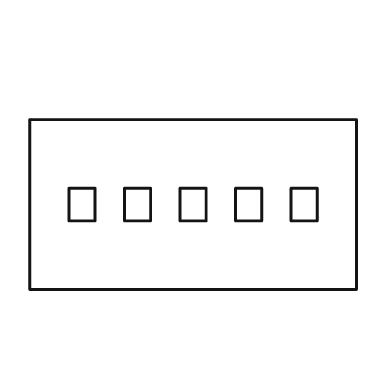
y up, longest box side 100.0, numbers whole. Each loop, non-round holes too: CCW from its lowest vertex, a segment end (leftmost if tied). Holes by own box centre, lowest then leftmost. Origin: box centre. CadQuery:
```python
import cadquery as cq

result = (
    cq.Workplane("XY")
    .moveTo(-50.0, -26.0)
    .lineTo(50.0, -26.0)
    .lineTo(50.0, 26.0)
    .lineTo(-50.0, 26.0)
    .close()
    .moveTo(-38.0, -5.0)
    .lineTo(-30.0, -5.0)
    .lineTo(-30.0, 5.0)
    .lineTo(-38.0, 5.0)
    .close()
    .moveTo(-21.0, -5.0)
    .lineTo(-13.0, -5.0)
    .lineTo(-13.0, 5.0)
    .lineTo(-21.0, 5.0)
    .close()
    .moveTo(-4.0, -5.0)
    .lineTo(4.0, -5.0)
    .lineTo(4.0, 5.0)
    .lineTo(-4.0, 5.0)
    .close()
    .moveTo(13.0, -5.0)
    .lineTo(21.0, -5.0)
    .lineTo(21.0, 5.0)
    .lineTo(13.0, 5.0)
    .close()
    .moveTo(30.0, -5.0)
    .lineTo(38.0, -5.0)
    .lineTo(38.0, 5.0)
    .lineTo(30.0, 5.0)
    .close()
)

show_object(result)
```